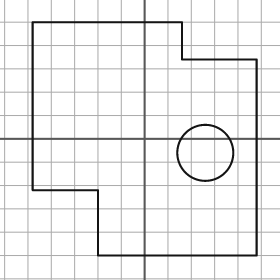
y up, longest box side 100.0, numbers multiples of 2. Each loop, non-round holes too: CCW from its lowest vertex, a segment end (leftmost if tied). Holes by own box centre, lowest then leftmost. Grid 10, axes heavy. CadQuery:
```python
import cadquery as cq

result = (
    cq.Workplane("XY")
    .moveTo(-20.0, -50.0)
    .lineTo(48.0, -50.0)
    .lineTo(48.0, 34.0)
    .lineTo(16.0, 34.0)
    .lineTo(16.0, 50.0)
    .lineTo(-48.0, 50.0)
    .lineTo(-48.0, -22.0)
    .lineTo(-20.0, -22.0)
    .close()
    .moveTo(26.0, -6.0)
    .circle(12.0)
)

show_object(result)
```